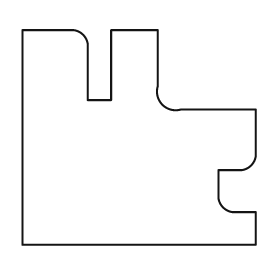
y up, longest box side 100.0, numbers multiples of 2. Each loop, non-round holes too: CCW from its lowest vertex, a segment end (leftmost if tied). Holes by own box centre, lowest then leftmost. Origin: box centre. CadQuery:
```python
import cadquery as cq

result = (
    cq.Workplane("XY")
    .moveTo(-50.0, -46.0)
    .lineTo(50.0, -46.0)
    .lineTo(50.0, -32.0)
    .lineTo(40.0, -32.0)
    .threePointArc((36.0, -30.0), (34.0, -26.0))
    .lineTo(34.0, -14.0)
    .lineTo(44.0, -14.0)
    .threePointArc((48.0, -12.0), (50.0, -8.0))
    .lineTo(50.0, 12.0)
    .lineTo(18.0, 12.0)
    .threePointArc((10.0, 14.0), (8.0, 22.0))
    .lineTo(8.0, 46.0)
    .lineTo(-12.0, 46.0)
    .lineTo(-12.0, 16.0)
    .lineTo(-22.0, 16.0)
    .lineTo(-22.0, 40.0)
    .threePointArc((-24.0, 44.0), (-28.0, 46.0))
    .lineTo(-50.0, 46.0)
    .close()
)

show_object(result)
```